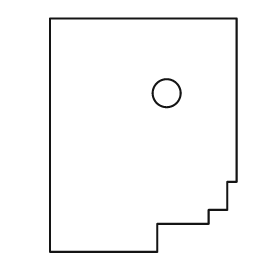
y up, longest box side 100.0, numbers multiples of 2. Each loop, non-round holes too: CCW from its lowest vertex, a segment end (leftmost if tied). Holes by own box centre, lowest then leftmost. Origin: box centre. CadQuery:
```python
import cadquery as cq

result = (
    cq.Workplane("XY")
    .moveTo(-40.0, -50.0)
    .lineTo(6.0, -50.0)
    .lineTo(6.0, -38.0)
    .lineTo(28.0, -38.0)
    .lineTo(28.0, -32.0)
    .lineTo(36.0, -32.0)
    .lineTo(36.0, -20.0)
    .lineTo(40.0, -20.0)
    .lineTo(40.0, 50.0)
    .lineTo(-40.0, 50.0)
    .close()
    .moveTo(10.0, 18.0)
    .circle(6.0)
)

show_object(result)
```